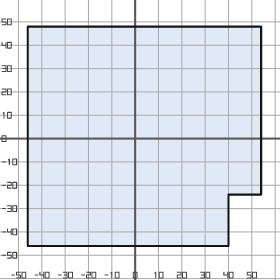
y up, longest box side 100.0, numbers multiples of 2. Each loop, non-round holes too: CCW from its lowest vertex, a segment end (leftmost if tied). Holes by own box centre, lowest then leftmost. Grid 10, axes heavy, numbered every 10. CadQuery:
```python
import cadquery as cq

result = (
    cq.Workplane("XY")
    .moveTo(-46.0, -46.0)
    .lineTo(40.0, -46.0)
    .lineTo(40.0, -24.0)
    .lineTo(54.0, -24.0)
    .lineTo(54.0, 48.0)
    .lineTo(-46.0, 48.0)
    .close()
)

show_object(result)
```